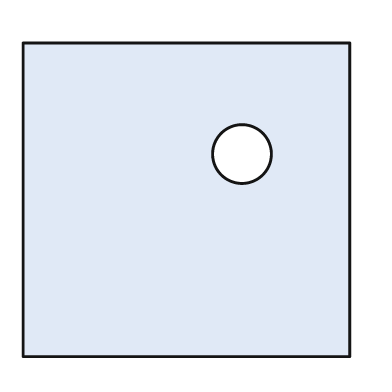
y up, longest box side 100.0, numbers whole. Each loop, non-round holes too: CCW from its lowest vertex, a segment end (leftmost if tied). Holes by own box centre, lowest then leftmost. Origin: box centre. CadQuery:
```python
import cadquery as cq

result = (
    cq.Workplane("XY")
    .moveTo(-50.0, -48.0)
    .lineTo(50.0, -48.0)
    .lineTo(50.0, 48.0)
    .lineTo(-50.0, 48.0)
    .close()
    .moveTo(17.0, 14.0)
    .circle(9.0)
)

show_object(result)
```